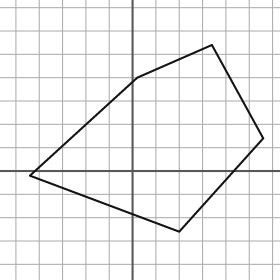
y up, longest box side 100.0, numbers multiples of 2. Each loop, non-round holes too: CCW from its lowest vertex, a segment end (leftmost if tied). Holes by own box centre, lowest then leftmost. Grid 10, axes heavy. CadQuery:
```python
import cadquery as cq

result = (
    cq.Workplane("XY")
    .moveTo(20.0, -26.0)
    .lineTo(56.0, 14.0)
    .lineTo(34.0, 54.0)
    .lineTo(2.0, 40.0)
    .lineTo(-44.0, -2.0)
    .close()
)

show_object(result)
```